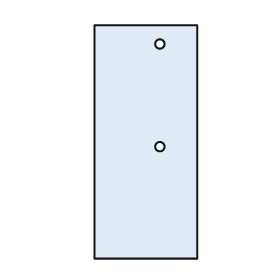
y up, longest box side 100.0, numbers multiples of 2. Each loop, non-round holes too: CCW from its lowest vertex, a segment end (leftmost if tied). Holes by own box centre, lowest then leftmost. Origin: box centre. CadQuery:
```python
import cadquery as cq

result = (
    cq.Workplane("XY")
    .moveTo(-22.0, -50.0)
    .lineTo(22.0, -50.0)
    .lineTo(22.0, 50.0)
    .lineTo(-22.0, 50.0)
    .close()
    .moveTo(6.0, -2.0)
    .circle(2.0)
    .moveTo(6.0, 42.0)
    .circle(2.0)
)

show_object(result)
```